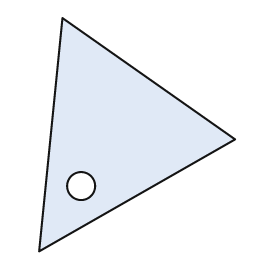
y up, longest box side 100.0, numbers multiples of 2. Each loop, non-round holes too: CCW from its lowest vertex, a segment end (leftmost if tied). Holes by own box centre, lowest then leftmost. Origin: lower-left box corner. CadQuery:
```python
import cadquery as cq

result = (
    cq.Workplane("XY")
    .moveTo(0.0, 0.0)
    .lineTo(84.0, 48.0)
    .lineTo(10.0, 100.0)
    .close()
    .moveTo(18.0, 28.0)
    .circle(6.0)
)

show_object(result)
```